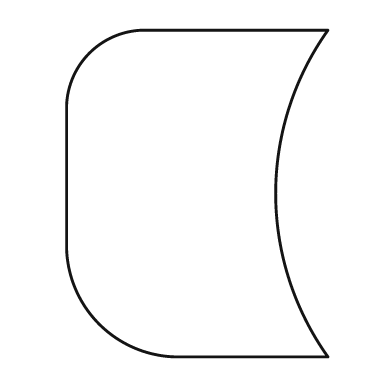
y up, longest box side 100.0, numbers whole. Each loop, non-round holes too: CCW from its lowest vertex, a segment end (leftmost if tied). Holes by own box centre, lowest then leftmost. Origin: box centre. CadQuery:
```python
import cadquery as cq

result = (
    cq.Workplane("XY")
    .moveTo(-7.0, -50.0)
    .lineTo(40.0, -50.0)
    .threePointArc((24.0, 0.0), (40.0, 50.0))
    .lineTo(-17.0, 50.0)
    .threePointArc((-33.0, 43.0), (-40.0, 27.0))
    .lineTo(-40.0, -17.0)
    .threePointArc((-30.0, -40.0), (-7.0, -50.0))
    .close()
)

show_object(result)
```